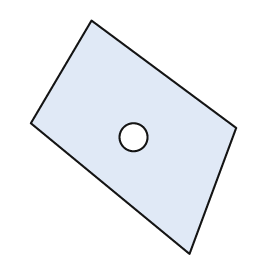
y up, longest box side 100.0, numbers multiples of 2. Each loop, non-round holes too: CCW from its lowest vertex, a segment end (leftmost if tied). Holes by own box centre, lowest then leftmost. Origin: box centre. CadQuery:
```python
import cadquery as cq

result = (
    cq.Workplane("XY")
    .moveTo(24.0, -50.0)
    .lineTo(44.0, 4.0)
    .lineTo(-18.0, 50.0)
    .lineTo(-44.0, 6.0)
    .close()
    .moveTo(0.0, 0.0)
    .circle(6.0)
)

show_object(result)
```